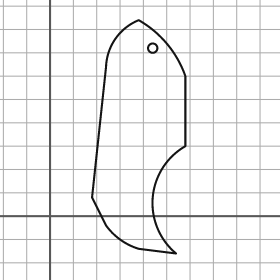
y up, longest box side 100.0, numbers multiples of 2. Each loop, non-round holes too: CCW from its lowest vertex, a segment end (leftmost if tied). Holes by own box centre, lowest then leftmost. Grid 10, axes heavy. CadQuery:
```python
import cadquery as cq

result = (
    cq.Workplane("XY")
    .moveTo(54.0, -16.0)
    .threePointArc((44.0, 8.0), (58.0, 30.0))
    .lineTo(58.0, 60.0)
    .threePointArc((50.0, 74.0), (38.0, 84.0))
    .threePointArc((28.0, 76.0), (24.0, 64.0))
    .lineTo(18.0, 8.0)
    .lineTo(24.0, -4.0)
    .threePointArc((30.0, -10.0), (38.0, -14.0))
    .close()
    .moveTo(44.0, 72.0)
    .circle(2.0)
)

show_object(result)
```